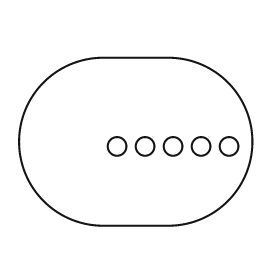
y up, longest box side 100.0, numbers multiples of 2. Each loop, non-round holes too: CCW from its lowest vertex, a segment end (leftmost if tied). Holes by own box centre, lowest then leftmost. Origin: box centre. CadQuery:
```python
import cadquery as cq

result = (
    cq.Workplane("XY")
    .moveTo(-14.0, -36.0)
    .lineTo(14.0, -36.0)
    .threePointArc((50.0, 0.0), (14.0, 36.0))
    .lineTo(-14.0, 36.0)
    .threePointArc((-50.0, 0.0), (-14.0, -36.0))
    .close()
    .moveTo(-8.0, -2.0)
    .circle(4.0)
    .moveTo(4.0, -2.0)
    .circle(4.0)
    .moveTo(16.0, -2.0)
    .circle(4.0)
    .moveTo(28.0, -2.0)
    .circle(4.0)
    .moveTo(40.0, -2.0)
    .circle(4.0)
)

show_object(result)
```